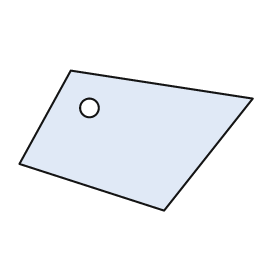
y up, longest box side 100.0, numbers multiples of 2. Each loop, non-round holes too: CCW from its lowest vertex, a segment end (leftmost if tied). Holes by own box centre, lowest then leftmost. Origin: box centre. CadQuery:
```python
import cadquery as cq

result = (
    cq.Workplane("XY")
    .moveTo(12.0, -30.0)
    .lineTo(50.0, 18.0)
    .lineTo(-28.0, 30.0)
    .lineTo(-50.0, -10.0)
    .close()
    .moveTo(-20.0, 14.0)
    .circle(4.0)
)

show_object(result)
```